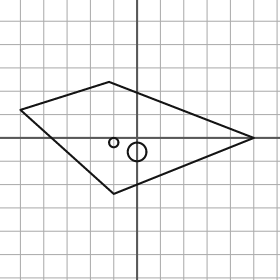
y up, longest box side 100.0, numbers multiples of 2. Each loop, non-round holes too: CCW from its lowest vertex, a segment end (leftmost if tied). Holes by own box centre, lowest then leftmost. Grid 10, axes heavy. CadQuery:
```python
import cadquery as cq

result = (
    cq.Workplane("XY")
    .moveTo(-10.0, -24.0)
    .lineTo(50.0, 0.0)
    .lineTo(-12.0, 24.0)
    .lineTo(-50.0, 12.0)
    .close()
    .moveTo(0.0, -6.0)
    .circle(4.0)
    .moveTo(-10.0, -2.0)
    .circle(2.0)
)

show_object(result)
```